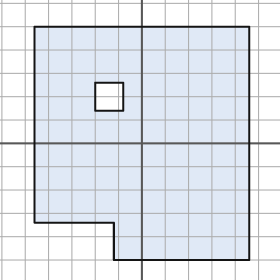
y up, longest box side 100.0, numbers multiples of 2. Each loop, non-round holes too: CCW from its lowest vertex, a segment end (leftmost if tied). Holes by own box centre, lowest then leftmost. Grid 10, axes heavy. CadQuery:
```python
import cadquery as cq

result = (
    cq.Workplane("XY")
    .moveTo(-12.0, -50.0)
    .lineTo(46.0, -50.0)
    .lineTo(46.0, 50.0)
    .lineTo(-46.0, 50.0)
    .lineTo(-46.0, -34.0)
    .lineTo(-12.0, -34.0)
    .close()
    .moveTo(-20.0, 14.0)
    .lineTo(-8.0, 14.0)
    .lineTo(-8.0, 26.0)
    .lineTo(-20.0, 26.0)
    .close()
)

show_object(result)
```